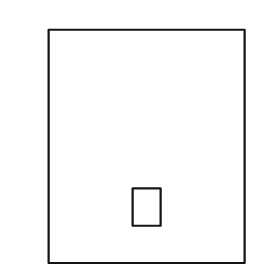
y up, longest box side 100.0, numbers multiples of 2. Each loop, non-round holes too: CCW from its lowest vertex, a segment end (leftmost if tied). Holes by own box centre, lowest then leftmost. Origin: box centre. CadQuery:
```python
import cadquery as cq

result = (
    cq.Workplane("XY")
    .moveTo(-42.0, -50.0)
    .lineTo(42.0, -50.0)
    .lineTo(42.0, 50.0)
    .lineTo(-42.0, 50.0)
    .close()
    .moveTo(-6.0, -34.0)
    .lineTo(6.0, -34.0)
    .lineTo(6.0, -18.0)
    .lineTo(-6.0, -18.0)
    .close()
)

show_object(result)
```